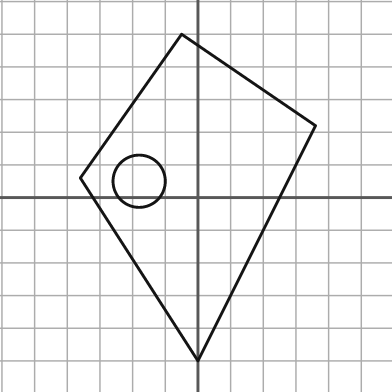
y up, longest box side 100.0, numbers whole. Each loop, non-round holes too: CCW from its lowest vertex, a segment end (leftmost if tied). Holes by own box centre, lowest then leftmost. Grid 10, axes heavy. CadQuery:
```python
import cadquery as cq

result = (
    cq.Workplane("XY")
    .moveTo(0.0, -50.0)
    .lineTo(36.0, 22.0)
    .lineTo(-5.0, 50.0)
    .lineTo(-36.0, 6.0)
    .close()
    .moveTo(-18.0, 5.0)
    .circle(8.0)
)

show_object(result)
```